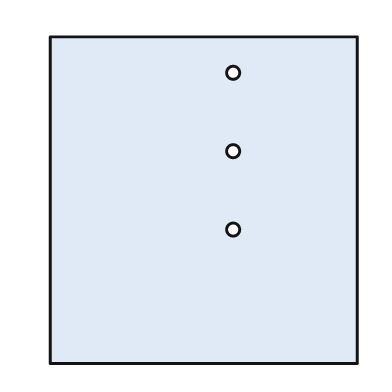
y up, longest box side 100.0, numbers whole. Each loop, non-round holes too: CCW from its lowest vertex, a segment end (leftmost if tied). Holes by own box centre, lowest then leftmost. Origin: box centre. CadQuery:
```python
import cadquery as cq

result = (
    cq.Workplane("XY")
    .moveTo(-47.0, -50.0)
    .lineTo(47.0, -50.0)
    .lineTo(47.0, 50.0)
    .lineTo(-47.0, 50.0)
    .close()
    .moveTo(9.0, -9.0)
    .circle(2.0)
    .moveTo(9.0, 15.0)
    .circle(2.0)
    .moveTo(9.0, 39.0)
    .circle(2.0)
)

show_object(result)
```